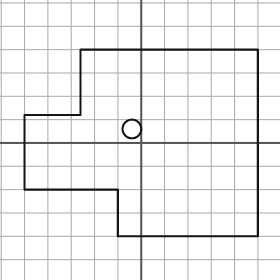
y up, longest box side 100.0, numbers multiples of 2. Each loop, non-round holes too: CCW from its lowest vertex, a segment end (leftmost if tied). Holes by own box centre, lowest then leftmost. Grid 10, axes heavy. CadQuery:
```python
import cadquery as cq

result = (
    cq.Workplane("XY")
    .moveTo(-10.0, -40.0)
    .lineTo(50.0, -40.0)
    .lineTo(50.0, 40.0)
    .lineTo(-26.0, 40.0)
    .lineTo(-26.0, 12.0)
    .lineTo(-50.0, 12.0)
    .lineTo(-50.0, -20.0)
    .lineTo(-10.0, -20.0)
    .close()
    .moveTo(-4.0, 6.0)
    .circle(4.0)
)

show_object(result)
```